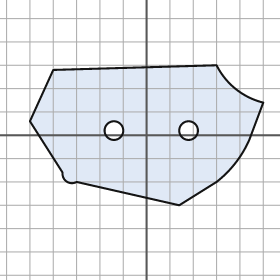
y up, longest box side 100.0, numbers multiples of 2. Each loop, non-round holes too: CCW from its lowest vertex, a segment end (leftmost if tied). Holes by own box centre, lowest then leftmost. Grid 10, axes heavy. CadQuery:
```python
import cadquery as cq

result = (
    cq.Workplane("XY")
    .moveTo(14.0, -30.0)
    .lineTo(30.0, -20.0)
    .threePointArc((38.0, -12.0), (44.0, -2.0))
    .lineTo(50.0, 14.0)
    .threePointArc((38.0, 20.0), (30.0, 30.0))
    .lineTo(-40.0, 28.0)
    .lineTo(-50.0, 6.0)
    .lineTo(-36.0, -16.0)
    .threePointArc((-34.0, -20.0), (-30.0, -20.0))
    .close()
    .moveTo(-14.0, 2.0)
    .circle(4.0)
    .moveTo(18.0, 2.0)
    .circle(4.0)
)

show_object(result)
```